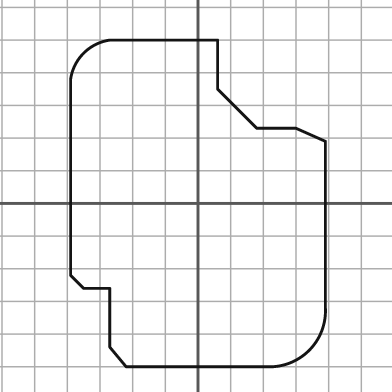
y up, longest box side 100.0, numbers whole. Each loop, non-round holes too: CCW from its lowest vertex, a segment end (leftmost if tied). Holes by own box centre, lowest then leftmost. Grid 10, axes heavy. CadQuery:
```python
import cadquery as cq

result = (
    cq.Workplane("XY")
    .moveTo(-22.0, -50.0)
    .lineTo(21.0, -50.0)
    .threePointArc((34.0, -45.0), (39.0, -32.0))
    .lineTo(39.0, 19.0)
    .lineTo(30.0, 23.0)
    .lineTo(18.0, 23.0)
    .lineTo(6.0, 35.0)
    .lineTo(6.0, 50.0)
    .lineTo(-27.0, 50.0)
    .threePointArc((-35.0, 46.0), (-39.0, 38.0))
    .lineTo(-39.0, -22.0)
    .lineTo(-35.0, -26.0)
    .lineTo(-27.0, -26.0)
    .lineTo(-27.0, -44.0)
    .close()
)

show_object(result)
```